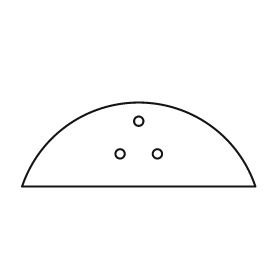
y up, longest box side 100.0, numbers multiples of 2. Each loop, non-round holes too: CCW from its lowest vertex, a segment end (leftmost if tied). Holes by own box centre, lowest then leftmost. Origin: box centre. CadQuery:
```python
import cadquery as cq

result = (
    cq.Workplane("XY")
    .moveTo(-50.0, -18.0)
    .lineTo(50.0, -18.0)
    .threePointArc((0.0, 18.0), (-50.0, -18.0))
    .close()
    .moveTo(-8.0, -4.0)
    .circle(2.0)
    .moveTo(8.0, -4.0)
    .circle(2.0)
    .moveTo(0.0, 10.0)
    .circle(2.0)
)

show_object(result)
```